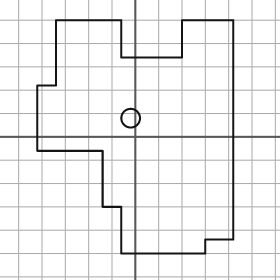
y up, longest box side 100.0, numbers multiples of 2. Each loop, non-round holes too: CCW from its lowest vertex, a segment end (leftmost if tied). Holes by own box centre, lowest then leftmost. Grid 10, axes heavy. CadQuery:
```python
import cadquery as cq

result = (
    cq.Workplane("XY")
    .moveTo(-6.0, -50.0)
    .lineTo(30.0, -50.0)
    .lineTo(30.0, -44.0)
    .lineTo(42.0, -44.0)
    .lineTo(42.0, 50.0)
    .lineTo(20.0, 50.0)
    .lineTo(20.0, 34.0)
    .lineTo(-6.0, 34.0)
    .lineTo(-6.0, 50.0)
    .lineTo(-34.0, 50.0)
    .lineTo(-34.0, 22.0)
    .lineTo(-42.0, 22.0)
    .lineTo(-42.0, -6.0)
    .lineTo(-14.0, -6.0)
    .lineTo(-14.0, -30.0)
    .lineTo(-6.0, -30.0)
    .close()
    .moveTo(-2.0, 8.0)
    .circle(4.0)
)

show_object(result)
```